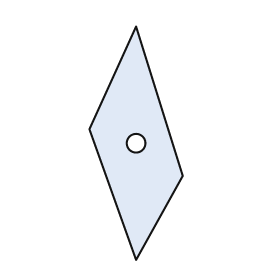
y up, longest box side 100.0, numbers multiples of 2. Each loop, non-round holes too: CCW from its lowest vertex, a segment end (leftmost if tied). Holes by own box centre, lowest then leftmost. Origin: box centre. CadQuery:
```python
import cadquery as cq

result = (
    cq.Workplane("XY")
    .moveTo(0.0, -50.0)
    .lineTo(20.0, -14.0)
    .lineTo(0.0, 50.0)
    .lineTo(-20.0, 6.0)
    .close()
    .moveTo(0.0, 0.0)
    .circle(4.0)
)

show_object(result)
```